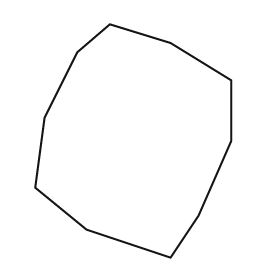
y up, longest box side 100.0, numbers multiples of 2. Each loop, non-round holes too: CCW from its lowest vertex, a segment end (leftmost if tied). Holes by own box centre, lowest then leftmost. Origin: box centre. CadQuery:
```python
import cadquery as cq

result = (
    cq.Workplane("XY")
    .moveTo(16.0, -50.0)
    .lineTo(28.0, -32.0)
    .lineTo(42.0, 0.0)
    .lineTo(42.0, 26.0)
    .lineTo(16.0, 42.0)
    .lineTo(-10.0, 50.0)
    .lineTo(-24.0, 38.0)
    .lineTo(-38.0, 10.0)
    .lineTo(-42.0, -20.0)
    .lineTo(-20.0, -38.0)
    .close()
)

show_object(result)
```